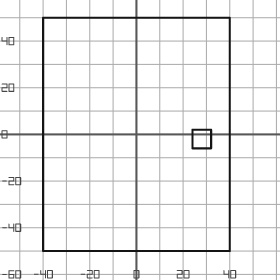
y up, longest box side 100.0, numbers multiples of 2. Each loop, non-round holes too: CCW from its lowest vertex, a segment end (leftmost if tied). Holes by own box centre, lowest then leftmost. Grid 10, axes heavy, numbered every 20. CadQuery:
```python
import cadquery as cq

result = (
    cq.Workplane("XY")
    .moveTo(-40.0, -50.0)
    .lineTo(40.0, -50.0)
    .lineTo(40.0, 50.0)
    .lineTo(-40.0, 50.0)
    .close()
    .moveTo(24.0, -6.0)
    .lineTo(32.0, -6.0)
    .lineTo(32.0, 2.0)
    .lineTo(24.0, 2.0)
    .close()
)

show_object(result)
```